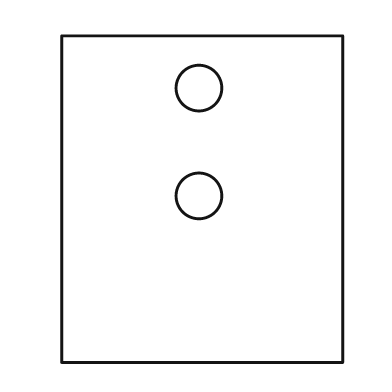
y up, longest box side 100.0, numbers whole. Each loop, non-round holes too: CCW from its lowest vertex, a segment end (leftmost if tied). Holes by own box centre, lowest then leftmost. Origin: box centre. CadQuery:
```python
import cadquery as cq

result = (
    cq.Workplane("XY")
    .moveTo(-43.0, -50.0)
    .lineTo(43.0, -50.0)
    .lineTo(43.0, 50.0)
    .lineTo(-43.0, 50.0)
    .close()
    .moveTo(-1.0, 1.0)
    .circle(7.0)
    .moveTo(-1.0, 34.0)
    .circle(7.0)
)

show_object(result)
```